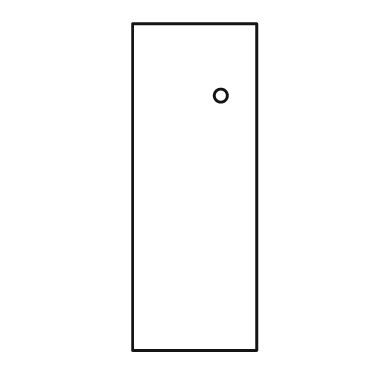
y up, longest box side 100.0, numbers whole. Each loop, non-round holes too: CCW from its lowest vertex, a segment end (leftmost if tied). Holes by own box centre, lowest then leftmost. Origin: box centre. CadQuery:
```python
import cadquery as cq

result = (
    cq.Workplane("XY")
    .moveTo(-19.0, -50.0)
    .lineTo(19.0, -50.0)
    .lineTo(19.0, 50.0)
    .lineTo(-19.0, 50.0)
    .close()
    .moveTo(8.0, 28.0)
    .circle(2.0)
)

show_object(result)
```